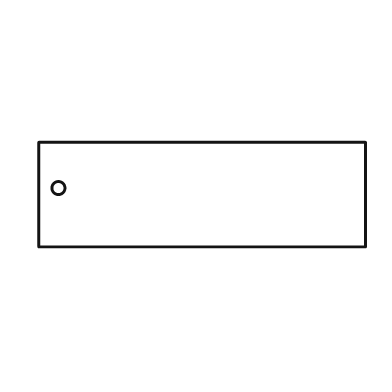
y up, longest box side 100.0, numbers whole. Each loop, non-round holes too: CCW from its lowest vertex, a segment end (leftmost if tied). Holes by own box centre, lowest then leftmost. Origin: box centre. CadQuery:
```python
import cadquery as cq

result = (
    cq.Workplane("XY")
    .moveTo(-50.0, -16.0)
    .lineTo(50.0, -16.0)
    .lineTo(50.0, 16.0)
    .lineTo(-50.0, 16.0)
    .close()
    .moveTo(-44.0, 2.0)
    .circle(2.0)
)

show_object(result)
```